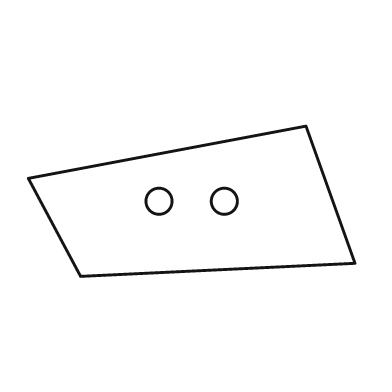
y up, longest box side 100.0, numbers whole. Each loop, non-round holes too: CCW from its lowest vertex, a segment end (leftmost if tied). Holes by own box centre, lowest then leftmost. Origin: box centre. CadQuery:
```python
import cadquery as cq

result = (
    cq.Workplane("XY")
    .moveTo(-34.0, -23.0)
    .lineTo(50.0, -19.0)
    .lineTo(35.0, 23.0)
    .lineTo(-50.0, 7.0)
    .close()
    .moveTo(-10.0, 0.0)
    .circle(4.0)
    .moveTo(10.0, 0.0)
    .circle(4.0)
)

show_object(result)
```